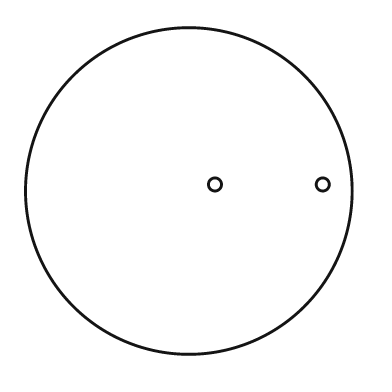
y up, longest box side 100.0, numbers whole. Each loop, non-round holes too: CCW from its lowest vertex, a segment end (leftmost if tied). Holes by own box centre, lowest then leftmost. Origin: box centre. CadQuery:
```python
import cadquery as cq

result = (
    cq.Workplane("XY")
    .moveTo(0.0, 0.0)
    .circle(50.0)
    .moveTo(8.0, 2.0)
    .circle(2.0)
    .moveTo(41.0, 2.0)
    .circle(2.0)
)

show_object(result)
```